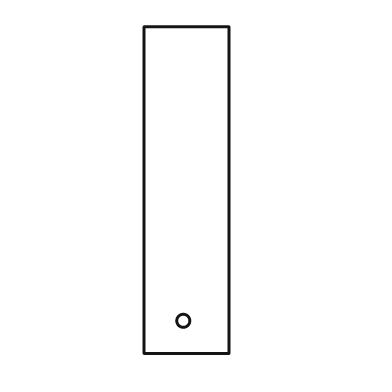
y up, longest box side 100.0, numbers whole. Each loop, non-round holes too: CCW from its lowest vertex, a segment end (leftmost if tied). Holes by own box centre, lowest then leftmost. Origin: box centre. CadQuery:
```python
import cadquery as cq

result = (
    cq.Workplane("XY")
    .moveTo(-13.0, -50.0)
    .lineTo(13.0, -50.0)
    .lineTo(13.0, 50.0)
    .lineTo(-13.0, 50.0)
    .close()
    .moveTo(-1.0, -40.0)
    .circle(2.0)
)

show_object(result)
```